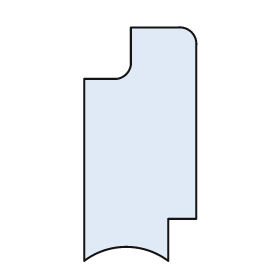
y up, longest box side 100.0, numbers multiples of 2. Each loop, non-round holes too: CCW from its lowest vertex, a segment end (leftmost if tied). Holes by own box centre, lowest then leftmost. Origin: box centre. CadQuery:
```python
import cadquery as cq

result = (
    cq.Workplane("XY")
    .moveTo(-24.0, -50.0)
    .threePointArc((-6.0, -44.0), (12.0, -50.0))
    .lineTo(12.0, -32.0)
    .lineTo(24.0, -32.0)
    .lineTo(24.0, 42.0)
    .threePointArc((22.0, 48.0), (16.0, 50.0))
    .lineTo(-4.0, 50.0)
    .lineTo(-4.0, 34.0)
    .threePointArc((-6.0, 30.0), (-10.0, 28.0))
    .lineTo(-24.0, 28.0)
    .close()
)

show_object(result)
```